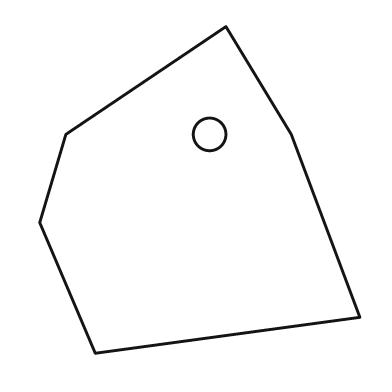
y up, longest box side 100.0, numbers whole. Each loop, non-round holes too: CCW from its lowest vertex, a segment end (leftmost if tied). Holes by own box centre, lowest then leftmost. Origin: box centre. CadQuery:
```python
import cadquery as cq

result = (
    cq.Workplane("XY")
    .moveTo(-32.0, -50.0)
    .lineTo(49.0, -39.0)
    .lineTo(28.0, 17.0)
    .lineTo(8.0, 50.0)
    .lineTo(-41.0, 17.0)
    .lineTo(-49.0, -10.0)
    .close()
    .moveTo(3.0, 17.0)
    .circle(5.0)
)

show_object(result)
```